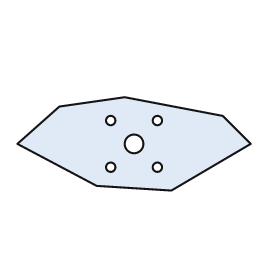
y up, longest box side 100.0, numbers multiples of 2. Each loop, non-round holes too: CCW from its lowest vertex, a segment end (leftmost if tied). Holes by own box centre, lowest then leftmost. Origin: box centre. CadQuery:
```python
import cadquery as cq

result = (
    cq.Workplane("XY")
    .moveTo(16.0, -20.0)
    .lineTo(50.0, 0.0)
    .lineTo(38.0, 12.0)
    .lineTo(-4.0, 20.0)
    .lineTo(-32.0, 16.0)
    .lineTo(-50.0, 0.0)
    .lineTo(-16.0, -18.0)
    .close()
    .moveTo(-10.0, -10.0)
    .circle(2.0)
    .moveTo(10.0, -10.0)
    .circle(2.0)
    .moveTo(0.0, 0.0)
    .circle(4.0)
    .moveTo(-10.0, 10.0)
    .circle(2.0)
    .moveTo(10.0, 10.0)
    .circle(2.0)
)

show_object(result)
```